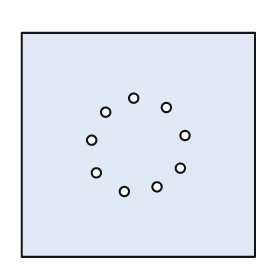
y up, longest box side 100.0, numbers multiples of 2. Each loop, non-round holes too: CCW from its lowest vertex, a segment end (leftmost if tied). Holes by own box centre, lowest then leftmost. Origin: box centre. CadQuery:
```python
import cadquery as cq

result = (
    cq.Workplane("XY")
    .moveTo(-50.0, -48.0)
    .lineTo(50.0, -48.0)
    .lineTo(50.0, 48.0)
    .lineTo(-50.0, 48.0)
    .close()
    .moveTo(-6.0, -20.0)
    .circle(2.0)
    .moveTo(8.0, -18.0)
    .circle(2.0)
    .moveTo(-18.0, -12.0)
    .circle(2.0)
    .moveTo(18.0, -10.0)
    .circle(2.0)
    .moveTo(-20.0, 2.0)
    .circle(2.0)
    .moveTo(20.0, 4.0)
    .circle(2.0)
    .moveTo(-14.0, 14.0)
    .circle(2.0)
    .moveTo(12.0, 16.0)
    .circle(2.0)
    .moveTo(-2.0, 20.0)
    .circle(2.0)
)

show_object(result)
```